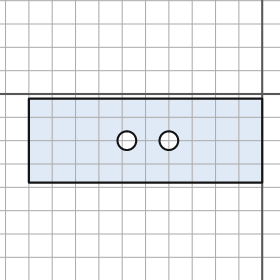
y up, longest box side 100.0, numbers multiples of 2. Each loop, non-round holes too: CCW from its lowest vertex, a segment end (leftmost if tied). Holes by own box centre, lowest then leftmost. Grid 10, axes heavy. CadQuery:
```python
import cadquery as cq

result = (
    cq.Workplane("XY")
    .moveTo(-100.0, -38.0)
    .lineTo(0.0, -38.0)
    .lineTo(0.0, -2.0)
    .lineTo(-100.0, -2.0)
    .close()
    .moveTo(-58.0, -20.0)
    .circle(4.0)
    .moveTo(-40.0, -20.0)
    .circle(4.0)
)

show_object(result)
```